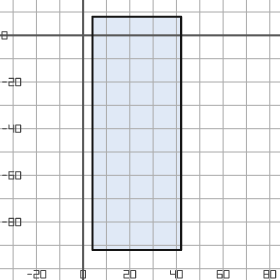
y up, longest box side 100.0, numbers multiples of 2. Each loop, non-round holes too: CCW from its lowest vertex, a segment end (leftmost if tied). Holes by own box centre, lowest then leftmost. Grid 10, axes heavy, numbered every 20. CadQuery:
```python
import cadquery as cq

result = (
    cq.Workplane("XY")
    .moveTo(4.0, -92.0)
    .lineTo(42.0, -92.0)
    .lineTo(42.0, 8.0)
    .lineTo(4.0, 8.0)
    .close()
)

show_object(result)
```